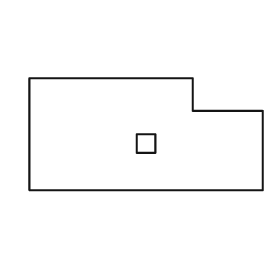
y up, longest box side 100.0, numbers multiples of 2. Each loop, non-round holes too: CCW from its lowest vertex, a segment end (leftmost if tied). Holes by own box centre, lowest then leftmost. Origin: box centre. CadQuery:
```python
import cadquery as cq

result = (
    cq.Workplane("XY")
    .moveTo(-50.0, -24.0)
    .lineTo(50.0, -24.0)
    .lineTo(50.0, 10.0)
    .lineTo(20.0, 10.0)
    .lineTo(20.0, 24.0)
    .lineTo(-50.0, 24.0)
    .close()
    .moveTo(-4.0, -8.0)
    .lineTo(4.0, -8.0)
    .lineTo(4.0, 0.0)
    .lineTo(-4.0, 0.0)
    .close()
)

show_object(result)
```